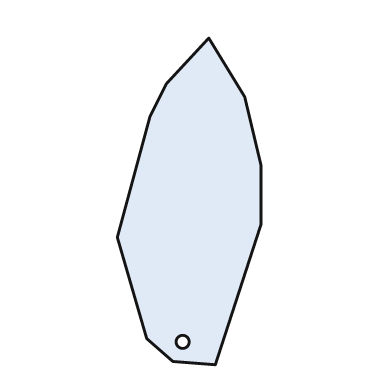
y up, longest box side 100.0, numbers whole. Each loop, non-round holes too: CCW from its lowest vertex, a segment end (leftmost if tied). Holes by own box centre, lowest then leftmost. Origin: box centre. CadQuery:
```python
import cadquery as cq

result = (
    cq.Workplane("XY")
    .moveTo(8.0, -50.0)
    .lineTo(22.0, -7.0)
    .lineTo(22.0, 11.0)
    .lineTo(17.0, 32.0)
    .lineTo(6.0, 50.0)
    .lineTo(-7.0, 36.0)
    .lineTo(-12.0, 26.0)
    .lineTo(-22.0, -11.0)
    .lineTo(-13.0, -42.0)
    .lineTo(-5.0, -49.0)
    .close()
    .moveTo(-2.0, -43.0)
    .circle(2.0)
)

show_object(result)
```